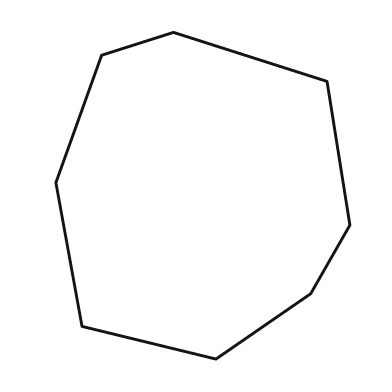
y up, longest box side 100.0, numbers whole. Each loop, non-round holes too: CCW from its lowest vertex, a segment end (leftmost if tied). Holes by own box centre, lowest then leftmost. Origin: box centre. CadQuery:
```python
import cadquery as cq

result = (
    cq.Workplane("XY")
    .moveTo(4.0, -50.0)
    .lineTo(33.0, -30.0)
    .lineTo(45.0, -9.0)
    .lineTo(38.0, 35.0)
    .lineTo(-9.0, 50.0)
    .lineTo(-31.0, 43.0)
    .lineTo(-45.0, 4.0)
    .lineTo(-37.0, -40.0)
    .close()
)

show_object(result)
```